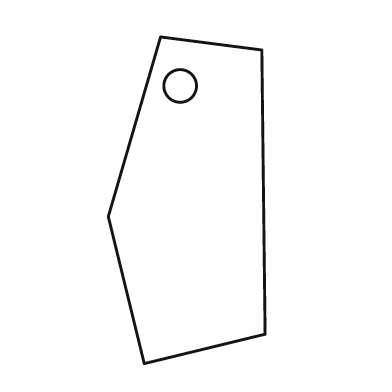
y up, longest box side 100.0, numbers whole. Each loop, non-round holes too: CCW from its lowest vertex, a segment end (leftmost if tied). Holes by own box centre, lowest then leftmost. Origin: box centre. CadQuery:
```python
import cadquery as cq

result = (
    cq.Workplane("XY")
    .moveTo(-13.0, -50.0)
    .lineTo(24.0, -41.0)
    .lineTo(23.0, 46.0)
    .lineTo(-8.0, 50.0)
    .lineTo(-24.0, -5.0)
    .close()
    .moveTo(-2.0, 35.0)
    .circle(5.0)
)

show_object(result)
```